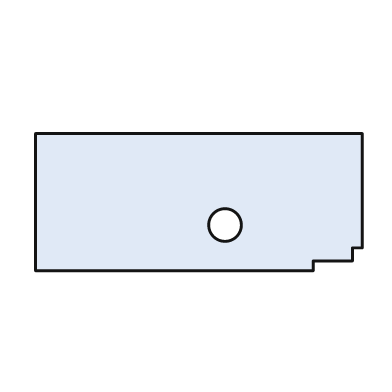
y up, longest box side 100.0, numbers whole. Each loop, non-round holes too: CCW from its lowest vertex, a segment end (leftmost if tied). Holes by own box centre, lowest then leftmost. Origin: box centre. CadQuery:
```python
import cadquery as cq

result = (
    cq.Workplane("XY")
    .moveTo(-50.0, -21.0)
    .lineTo(35.0, -21.0)
    .lineTo(35.0, -18.0)
    .lineTo(47.0, -18.0)
    .lineTo(47.0, -14.0)
    .lineTo(50.0, -14.0)
    .lineTo(50.0, 21.0)
    .lineTo(-50.0, 21.0)
    .close()
    .moveTo(8.0, -7.0)
    .circle(5.0)
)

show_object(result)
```